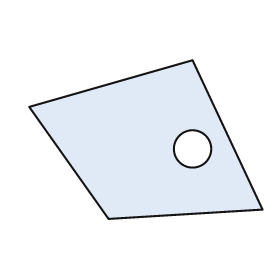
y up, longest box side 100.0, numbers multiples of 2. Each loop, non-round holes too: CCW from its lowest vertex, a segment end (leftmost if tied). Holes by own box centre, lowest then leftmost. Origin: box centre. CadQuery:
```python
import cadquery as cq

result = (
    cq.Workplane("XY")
    .moveTo(-16.0, -34.0)
    .lineTo(50.0, -30.0)
    .lineTo(20.0, 34.0)
    .lineTo(-50.0, 14.0)
    .close()
    .moveTo(20.0, -4.0)
    .circle(8.0)
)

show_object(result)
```